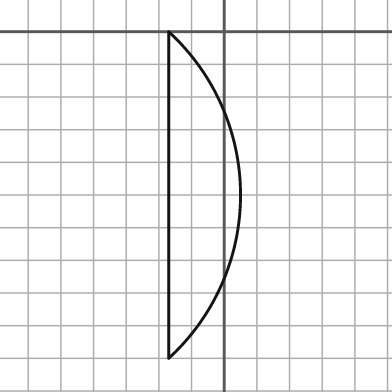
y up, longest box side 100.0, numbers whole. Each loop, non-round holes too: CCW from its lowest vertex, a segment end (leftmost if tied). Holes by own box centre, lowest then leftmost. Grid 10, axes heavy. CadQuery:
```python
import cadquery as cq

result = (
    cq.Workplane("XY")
    .moveTo(-17.0, -100.0)
    .threePointArc((5.0, -50.0), (-17.0, 0.0))
    .close()
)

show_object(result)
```